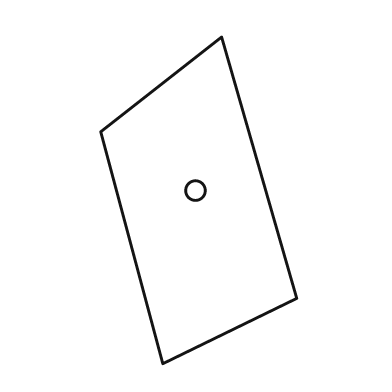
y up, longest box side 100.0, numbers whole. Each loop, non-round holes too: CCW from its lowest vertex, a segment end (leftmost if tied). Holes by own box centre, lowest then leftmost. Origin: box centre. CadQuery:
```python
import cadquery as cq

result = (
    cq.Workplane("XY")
    .moveTo(-11.0, -50.0)
    .lineTo(30.0, -30.0)
    .lineTo(7.0, 50.0)
    .lineTo(-30.0, 21.0)
    .close()
    .moveTo(-1.0, 3.0)
    .circle(3.0)
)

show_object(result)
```